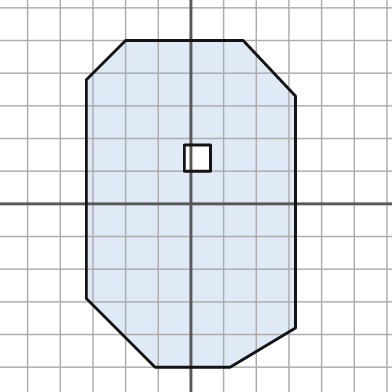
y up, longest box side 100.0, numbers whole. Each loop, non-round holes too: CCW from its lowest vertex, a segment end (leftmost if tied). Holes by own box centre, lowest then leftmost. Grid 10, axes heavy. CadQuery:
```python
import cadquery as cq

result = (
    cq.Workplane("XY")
    .moveTo(-11.0, -50.0)
    .lineTo(12.0, -50.0)
    .lineTo(32.0, -38.0)
    .lineTo(32.0, 33.0)
    .lineTo(16.0, 50.0)
    .lineTo(-20.0, 50.0)
    .lineTo(-32.0, 38.0)
    .lineTo(-32.0, -29.0)
    .close()
    .moveTo(-2.0, 10.0)
    .lineTo(6.0, 10.0)
    .lineTo(6.0, 18.0)
    .lineTo(-2.0, 18.0)
    .close()
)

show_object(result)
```